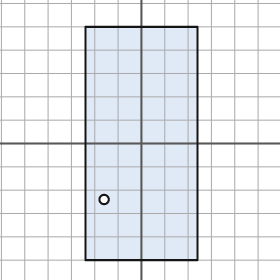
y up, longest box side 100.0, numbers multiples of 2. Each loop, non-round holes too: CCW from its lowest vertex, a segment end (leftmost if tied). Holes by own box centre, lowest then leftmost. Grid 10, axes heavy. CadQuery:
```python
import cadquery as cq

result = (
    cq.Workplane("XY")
    .moveTo(-24.0, -50.0)
    .lineTo(24.0, -50.0)
    .lineTo(24.0, 50.0)
    .lineTo(-24.0, 50.0)
    .close()
    .moveTo(-16.0, -24.0)
    .circle(2.0)
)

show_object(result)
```